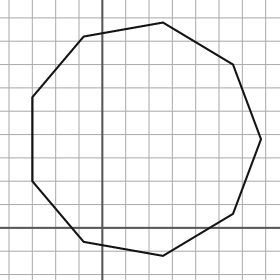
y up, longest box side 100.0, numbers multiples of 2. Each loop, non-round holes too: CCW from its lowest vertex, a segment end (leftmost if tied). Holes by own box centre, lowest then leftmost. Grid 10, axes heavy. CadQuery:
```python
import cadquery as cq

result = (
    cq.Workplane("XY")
    .moveTo(26.0, -12.0)
    .lineTo(56.0, 6.0)
    .lineTo(68.0, 38.0)
    .lineTo(56.0, 70.0)
    .lineTo(26.0, 88.0)
    .lineTo(-8.0, 82.0)
    .lineTo(-30.0, 56.0)
    .lineTo(-30.0, 20.0)
    .lineTo(-8.0, -6.0)
    .close()
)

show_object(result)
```